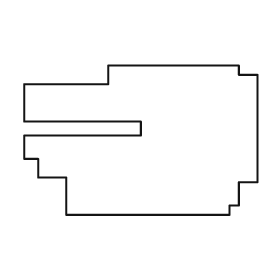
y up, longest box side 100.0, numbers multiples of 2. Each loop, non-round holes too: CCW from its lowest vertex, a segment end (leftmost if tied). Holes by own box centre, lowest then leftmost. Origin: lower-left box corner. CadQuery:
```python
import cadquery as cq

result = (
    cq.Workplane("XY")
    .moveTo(18.0, 0.0)
    .lineTo(88.0, 0.0)
    .lineTo(88.0, 4.0)
    .lineTo(92.0, 4.0)
    .lineTo(92.0, 14.0)
    .lineTo(100.0, 14.0)
    .lineTo(100.0, 60.0)
    .lineTo(92.0, 60.0)
    .lineTo(92.0, 64.0)
    .lineTo(36.0, 64.0)
    .lineTo(36.0, 56.0)
    .lineTo(0.0, 56.0)
    .lineTo(0.0, 40.0)
    .lineTo(50.0, 40.0)
    .lineTo(50.0, 34.0)
    .lineTo(0.0, 34.0)
    .lineTo(0.0, 24.0)
    .lineTo(6.0, 24.0)
    .lineTo(6.0, 16.0)
    .lineTo(18.0, 16.0)
    .close()
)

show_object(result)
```